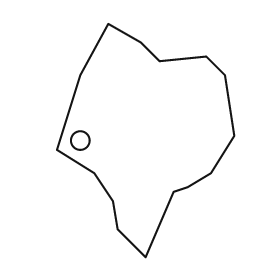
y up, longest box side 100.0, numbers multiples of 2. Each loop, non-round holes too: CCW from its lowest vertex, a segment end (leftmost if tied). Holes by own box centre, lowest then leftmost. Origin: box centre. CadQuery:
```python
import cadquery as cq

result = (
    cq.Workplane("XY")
    .moveTo(0.0, -50.0)
    .lineTo(12.0, -22.0)
    .lineTo(18.0, -20.0)
    .lineTo(28.0, -14.0)
    .lineTo(38.0, 2.0)
    .lineTo(34.0, 28.0)
    .lineTo(26.0, 36.0)
    .lineTo(6.0, 34.0)
    .lineTo(-2.0, 42.0)
    .lineTo(-16.0, 50.0)
    .lineTo(-28.0, 28.0)
    .lineTo(-38.0, -4.0)
    .lineTo(-22.0, -14.0)
    .lineTo(-14.0, -26.0)
    .lineTo(-12.0, -38.0)
    .close()
    .moveTo(-28.0, 0.0)
    .circle(4.0)
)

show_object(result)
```